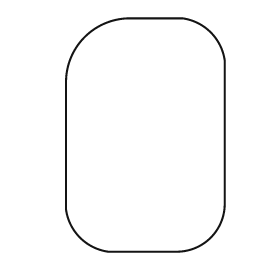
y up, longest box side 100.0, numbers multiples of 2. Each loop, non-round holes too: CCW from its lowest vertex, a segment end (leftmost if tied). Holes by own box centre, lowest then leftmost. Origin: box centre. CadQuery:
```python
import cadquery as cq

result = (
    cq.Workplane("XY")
    .moveTo(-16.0, -50.0)
    .lineTo(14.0, -50.0)
    .threePointArc((28.0, -44.0), (34.0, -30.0))
    .lineTo(34.0, 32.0)
    .threePointArc((28.0, 44.0), (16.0, 50.0))
    .lineTo(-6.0, 50.0)
    .threePointArc((-26.0, 42.0), (-34.0, 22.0))
    .lineTo(-34.0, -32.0)
    .threePointArc((-28.0, -44.0), (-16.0, -50.0))
    .close()
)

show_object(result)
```